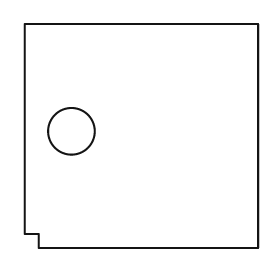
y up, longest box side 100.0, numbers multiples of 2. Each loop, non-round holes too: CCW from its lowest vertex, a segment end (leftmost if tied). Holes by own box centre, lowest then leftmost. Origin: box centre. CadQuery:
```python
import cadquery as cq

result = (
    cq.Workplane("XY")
    .moveTo(-44.0, -48.0)
    .lineTo(50.0, -48.0)
    .lineTo(50.0, 48.0)
    .lineTo(-50.0, 48.0)
    .lineTo(-50.0, -42.0)
    .lineTo(-44.0, -42.0)
    .close()
    .moveTo(-30.0, 2.0)
    .circle(10.0)
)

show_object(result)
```